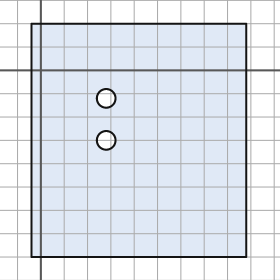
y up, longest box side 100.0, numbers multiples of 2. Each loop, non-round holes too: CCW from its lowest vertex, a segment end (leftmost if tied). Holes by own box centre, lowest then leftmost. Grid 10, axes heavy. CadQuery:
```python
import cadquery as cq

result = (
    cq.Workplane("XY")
    .moveTo(-4.0, -80.0)
    .lineTo(88.0, -80.0)
    .lineTo(88.0, 20.0)
    .lineTo(-4.0, 20.0)
    .close()
    .moveTo(28.0, -30.0)
    .circle(4.0)
    .moveTo(28.0, -12.0)
    .circle(4.0)
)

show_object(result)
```